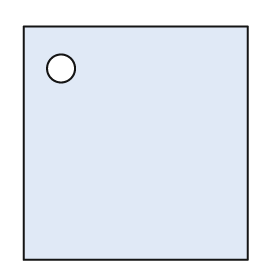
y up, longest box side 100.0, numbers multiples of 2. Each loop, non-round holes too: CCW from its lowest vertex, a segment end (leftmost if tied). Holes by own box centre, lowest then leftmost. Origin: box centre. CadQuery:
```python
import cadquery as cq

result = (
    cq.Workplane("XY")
    .moveTo(-48.0, -50.0)
    .lineTo(48.0, -50.0)
    .lineTo(48.0, 50.0)
    .lineTo(-48.0, 50.0)
    .close()
    .moveTo(-32.0, 32.0)
    .circle(6.0)
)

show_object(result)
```